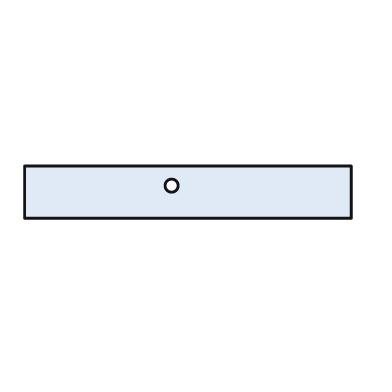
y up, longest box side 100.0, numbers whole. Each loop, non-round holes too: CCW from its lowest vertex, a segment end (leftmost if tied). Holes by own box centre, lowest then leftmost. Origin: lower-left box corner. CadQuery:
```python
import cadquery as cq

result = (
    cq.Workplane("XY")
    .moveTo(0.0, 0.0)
    .lineTo(100.0, 0.0)
    .lineTo(100.0, 16.0)
    .lineTo(0.0, 16.0)
    .close()
    .moveTo(45.0, 10.0)
    .circle(2.0)
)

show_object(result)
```